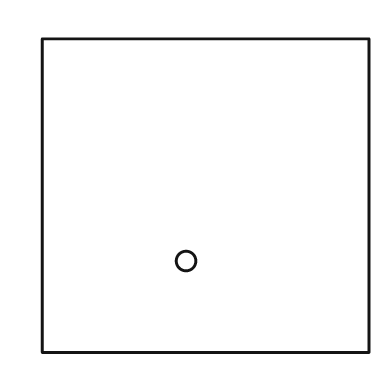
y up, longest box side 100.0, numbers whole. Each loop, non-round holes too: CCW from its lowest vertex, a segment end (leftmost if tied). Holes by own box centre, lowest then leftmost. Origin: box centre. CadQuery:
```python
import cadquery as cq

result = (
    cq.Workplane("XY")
    .moveTo(-50.0, -48.0)
    .lineTo(50.0, -48.0)
    .lineTo(50.0, 48.0)
    .lineTo(-50.0, 48.0)
    .close()
    .moveTo(-6.0, -20.0)
    .circle(3.0)
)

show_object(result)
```